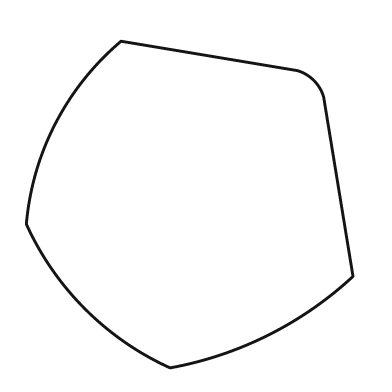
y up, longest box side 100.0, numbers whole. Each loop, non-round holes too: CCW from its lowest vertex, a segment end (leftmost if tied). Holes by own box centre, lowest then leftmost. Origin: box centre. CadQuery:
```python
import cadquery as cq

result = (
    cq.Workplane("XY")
    .moveTo(-6.0, -50.0)
    .threePointArc((24.0, -40.0), (50.0, -22.0))
    .lineTo(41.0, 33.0)
    .threePointArc((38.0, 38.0), (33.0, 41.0))
    .lineTo(-21.0, 50.0)
    .threePointArc((-41.0, 25.0), (-50.0, -6.0))
    .threePointArc((-32.0, -32.0), (-6.0, -50.0))
    .close()
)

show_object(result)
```